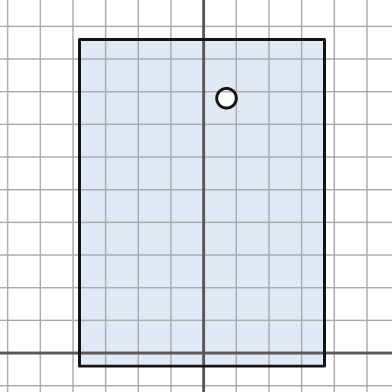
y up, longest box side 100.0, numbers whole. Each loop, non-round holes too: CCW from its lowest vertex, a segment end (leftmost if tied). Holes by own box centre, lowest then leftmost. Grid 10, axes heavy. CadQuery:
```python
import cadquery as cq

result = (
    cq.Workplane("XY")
    .moveTo(-38.0, -4.0)
    .lineTo(37.0, -4.0)
    .lineTo(37.0, 96.0)
    .lineTo(-38.0, 96.0)
    .close()
    .moveTo(7.0, 78.0)
    .circle(3.0)
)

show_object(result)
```